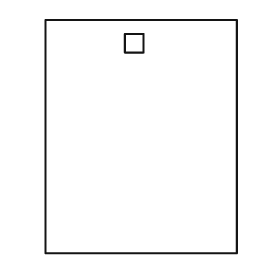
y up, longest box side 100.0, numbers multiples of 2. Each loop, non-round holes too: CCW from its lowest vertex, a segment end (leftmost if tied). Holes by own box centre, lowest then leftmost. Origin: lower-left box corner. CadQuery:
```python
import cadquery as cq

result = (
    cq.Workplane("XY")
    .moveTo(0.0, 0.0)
    .lineTo(82.0, 0.0)
    .lineTo(82.0, 100.0)
    .lineTo(0.0, 100.0)
    .close()
    .moveTo(34.0, 86.0)
    .lineTo(42.0, 86.0)
    .lineTo(42.0, 94.0)
    .lineTo(34.0, 94.0)
    .close()
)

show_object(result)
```